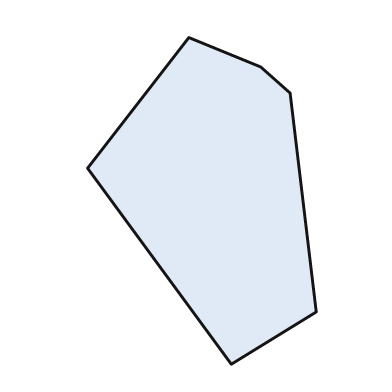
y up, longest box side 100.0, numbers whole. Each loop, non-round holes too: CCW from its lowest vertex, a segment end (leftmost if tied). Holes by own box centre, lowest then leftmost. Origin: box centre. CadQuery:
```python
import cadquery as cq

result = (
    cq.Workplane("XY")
    .moveTo(9.0, -50.0)
    .lineTo(35.0, -34.0)
    .lineTo(27.0, 33.0)
    .lineTo(18.0, 41.0)
    .lineTo(-4.0, 50.0)
    .lineTo(-35.0, 10.0)
    .close()
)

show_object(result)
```